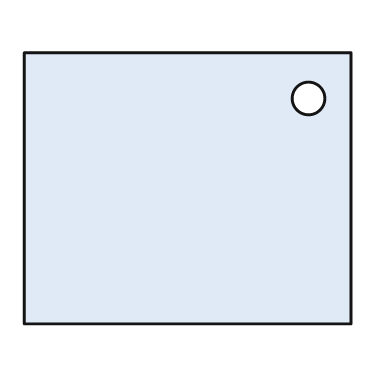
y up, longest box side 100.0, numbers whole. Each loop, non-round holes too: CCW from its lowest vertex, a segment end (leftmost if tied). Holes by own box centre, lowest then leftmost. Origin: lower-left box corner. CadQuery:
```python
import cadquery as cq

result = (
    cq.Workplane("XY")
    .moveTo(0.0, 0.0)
    .lineTo(100.0, 0.0)
    .lineTo(100.0, 83.0)
    .lineTo(0.0, 83.0)
    .close()
    .moveTo(87.0, 69.0)
    .circle(5.0)
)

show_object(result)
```